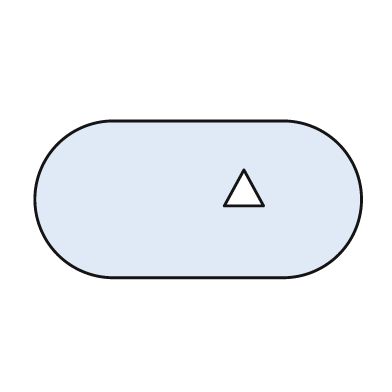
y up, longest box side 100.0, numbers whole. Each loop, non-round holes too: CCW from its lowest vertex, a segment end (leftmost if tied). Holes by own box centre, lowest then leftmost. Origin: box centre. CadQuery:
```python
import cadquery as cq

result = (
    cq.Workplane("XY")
    .moveTo(-26.0, -24.0)
    .lineTo(26.0, -24.0)
    .threePointArc((50.0, 0.0), (26.0, 24.0))
    .lineTo(-26.0, 24.0)
    .threePointArc((-50.0, 0.0), (-26.0, -24.0))
    .close()
    .moveTo(8.0, -2.0)
    .lineTo(20.0, -2.0)
    .lineTo(14.0, 9.0)
    .close()
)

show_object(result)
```